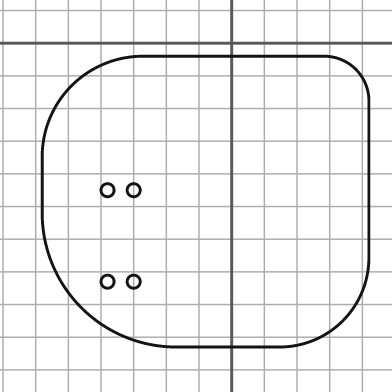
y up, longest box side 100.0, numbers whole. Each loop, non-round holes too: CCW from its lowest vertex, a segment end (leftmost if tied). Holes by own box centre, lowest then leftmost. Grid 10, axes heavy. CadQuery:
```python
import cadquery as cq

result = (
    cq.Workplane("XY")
    .moveTo(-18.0, -93.0)
    .lineTo(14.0, -93.0)
    .threePointArc((34.0, -85.0), (42.0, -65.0))
    .lineTo(42.0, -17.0)
    .threePointArc((38.0, -8.0), (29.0, -4.0))
    .lineTo(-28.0, -4.0)
    .threePointArc((-49.0, -13.0), (-58.0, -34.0))
    .lineTo(-58.0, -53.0)
    .threePointArc((-46.0, -81.0), (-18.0, -93.0))
    .close()
    .moveTo(-38.0, -73.0)
    .circle(2.0)
    .moveTo(-30.0, -73.0)
    .circle(2.0)
    .moveTo(-38.0, -45.0)
    .circle(2.0)
    .moveTo(-30.0, -45.0)
    .circle(2.0)
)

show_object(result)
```